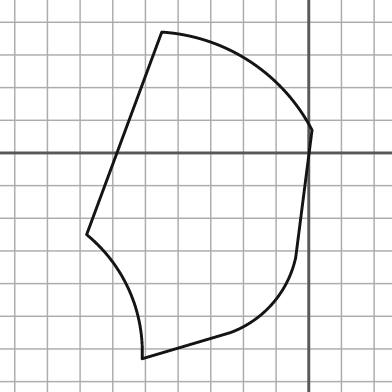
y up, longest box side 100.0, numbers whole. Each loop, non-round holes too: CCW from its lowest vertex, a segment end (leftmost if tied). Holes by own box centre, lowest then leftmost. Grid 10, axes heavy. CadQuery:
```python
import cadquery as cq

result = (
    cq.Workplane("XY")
    .moveTo(-51.0, -63.0)
    .lineTo(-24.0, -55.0)
    .threePointArc((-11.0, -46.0), (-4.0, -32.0))
    .lineTo(1.0, 7.0)
    .threePointArc((-18.0, 28.0), (-45.0, 37.0))
    .lineTo(-68.0, -25.0)
    .threePointArc((-55.0, -42.0), (-51.0, -63.0))
    .close()
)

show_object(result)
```